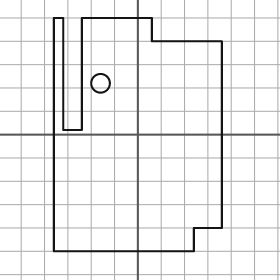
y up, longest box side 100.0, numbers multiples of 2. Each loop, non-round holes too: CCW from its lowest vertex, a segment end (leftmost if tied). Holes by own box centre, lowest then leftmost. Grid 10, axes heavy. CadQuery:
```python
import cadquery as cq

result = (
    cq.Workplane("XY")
    .moveTo(-36.0, -50.0)
    .lineTo(24.0, -50.0)
    .lineTo(24.0, -40.0)
    .lineTo(36.0, -40.0)
    .lineTo(36.0, 40.0)
    .lineTo(6.0, 40.0)
    .lineTo(6.0, 50.0)
    .lineTo(-24.0, 50.0)
    .lineTo(-24.0, 2.0)
    .lineTo(-32.0, 2.0)
    .lineTo(-32.0, 50.0)
    .lineTo(-36.0, 50.0)
    .close()
    .moveTo(-16.0, 22.0)
    .circle(4.0)
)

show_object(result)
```